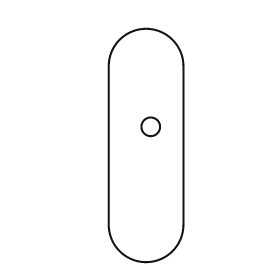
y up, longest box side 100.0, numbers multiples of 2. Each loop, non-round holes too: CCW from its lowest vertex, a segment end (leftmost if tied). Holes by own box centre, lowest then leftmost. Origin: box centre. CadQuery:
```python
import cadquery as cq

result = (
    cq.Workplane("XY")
    .moveTo(-16.0, -34.0)
    .threePointArc((0.0, -50.0), (16.0, -34.0))
    .lineTo(16.0, 34.0)
    .threePointArc((0.0, 50.0), (-16.0, 34.0))
    .close()
    .moveTo(2.0, 8.0)
    .circle(4.0)
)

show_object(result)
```